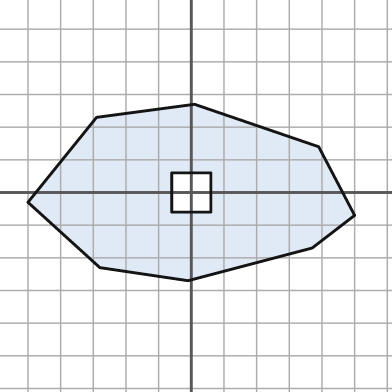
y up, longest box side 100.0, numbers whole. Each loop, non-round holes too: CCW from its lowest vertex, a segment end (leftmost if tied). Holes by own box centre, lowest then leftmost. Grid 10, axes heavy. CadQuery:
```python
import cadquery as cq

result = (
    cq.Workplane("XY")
    .moveTo(-1.0, -27.0)
    .lineTo(37.0, -17.0)
    .lineTo(50.0, -7.0)
    .lineTo(39.0, 14.0)
    .lineTo(1.0, 27.0)
    .lineTo(-29.0, 23.0)
    .lineTo(-50.0, -3.0)
    .lineTo(-28.0, -23.0)
    .close()
    .moveTo(-6.0, -6.0)
    .lineTo(6.0, -6.0)
    .lineTo(6.0, 6.0)
    .lineTo(-6.0, 6.0)
    .close()
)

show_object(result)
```